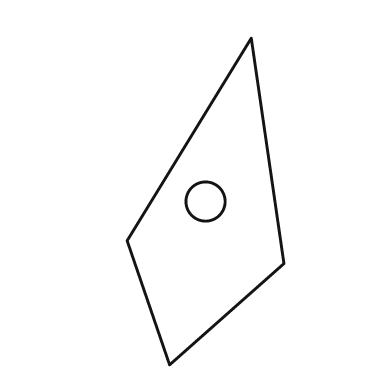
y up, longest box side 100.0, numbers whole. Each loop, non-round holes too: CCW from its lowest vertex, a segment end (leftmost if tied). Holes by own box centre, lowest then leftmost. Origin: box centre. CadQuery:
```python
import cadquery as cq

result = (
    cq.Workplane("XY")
    .moveTo(-11.0, -50.0)
    .lineTo(24.0, -19.0)
    .lineTo(14.0, 50.0)
    .lineTo(-24.0, -12.0)
    .close()
    .moveTo(0.0, 0.0)
    .circle(6.0)
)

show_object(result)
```